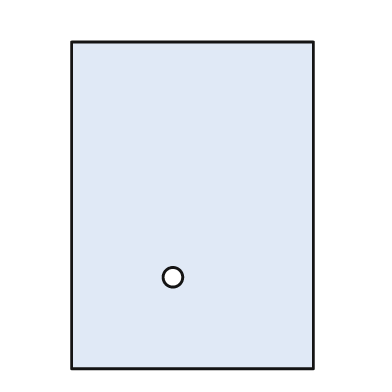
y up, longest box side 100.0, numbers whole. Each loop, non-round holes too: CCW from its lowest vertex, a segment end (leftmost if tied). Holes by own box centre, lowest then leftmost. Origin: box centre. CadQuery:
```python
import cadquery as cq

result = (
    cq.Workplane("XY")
    .moveTo(-37.0, -50.0)
    .lineTo(37.0, -50.0)
    .lineTo(37.0, 50.0)
    .lineTo(-37.0, 50.0)
    .close()
    .moveTo(-6.0, -22.0)
    .circle(3.0)
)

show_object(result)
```